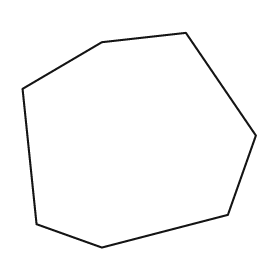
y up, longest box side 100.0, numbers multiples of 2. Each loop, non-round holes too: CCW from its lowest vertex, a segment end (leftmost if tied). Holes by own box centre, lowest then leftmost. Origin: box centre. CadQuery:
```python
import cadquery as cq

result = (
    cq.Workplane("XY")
    .moveTo(-16.0, -46.0)
    .lineTo(38.0, -32.0)
    .lineTo(50.0, 2.0)
    .lineTo(20.0, 46.0)
    .lineTo(-16.0, 42.0)
    .lineTo(-50.0, 22.0)
    .lineTo(-44.0, -36.0)
    .close()
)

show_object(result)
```